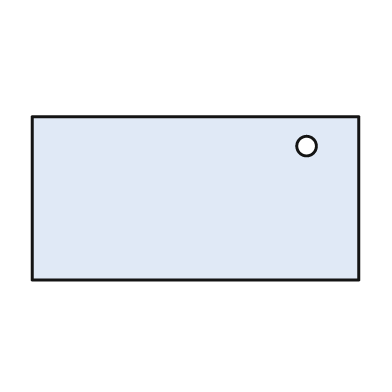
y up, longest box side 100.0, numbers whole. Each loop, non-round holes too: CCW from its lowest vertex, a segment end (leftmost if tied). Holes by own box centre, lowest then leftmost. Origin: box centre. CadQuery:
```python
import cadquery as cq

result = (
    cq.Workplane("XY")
    .moveTo(-50.0, -25.0)
    .lineTo(50.0, -25.0)
    .lineTo(50.0, 25.0)
    .lineTo(-50.0, 25.0)
    .close()
    .moveTo(34.0, 16.0)
    .circle(3.0)
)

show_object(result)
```